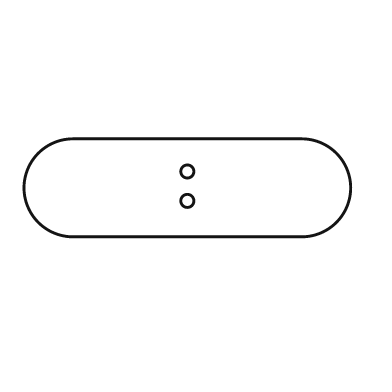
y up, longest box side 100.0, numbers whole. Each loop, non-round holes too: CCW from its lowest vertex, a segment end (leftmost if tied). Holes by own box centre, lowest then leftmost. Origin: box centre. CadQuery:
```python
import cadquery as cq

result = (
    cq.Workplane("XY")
    .moveTo(-35.0, -15.0)
    .lineTo(35.0, -15.0)
    .threePointArc((50.0, 0.0), (35.0, 15.0))
    .lineTo(-35.0, 15.0)
    .threePointArc((-50.0, 0.0), (-35.0, -15.0))
    .close()
    .moveTo(0.0, -4.0)
    .circle(2.0)
    .moveTo(0.0, 5.0)
    .circle(2.0)
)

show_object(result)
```